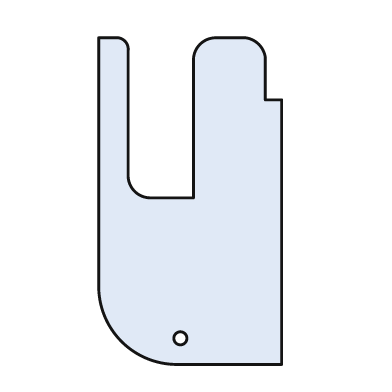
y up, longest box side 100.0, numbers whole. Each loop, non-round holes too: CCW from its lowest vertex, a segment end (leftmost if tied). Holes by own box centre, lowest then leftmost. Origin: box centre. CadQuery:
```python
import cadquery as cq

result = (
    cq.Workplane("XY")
    .moveTo(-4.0, -50.0)
    .lineTo(28.0, -50.0)
    .lineTo(28.0, 31.0)
    .lineTo(23.0, 31.0)
    .lineTo(23.0, 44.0)
    .threePointArc((21.0, 48.0), (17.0, 50.0))
    .lineTo(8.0, 50.0)
    .threePointArc((3.0, 48.0), (1.0, 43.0))
    .lineTo(1.0, 1.0)
    .lineTo(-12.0, 1.0)
    .threePointArc((-17.0, 3.0), (-19.0, 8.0))
    .lineTo(-19.0, 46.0)
    .threePointArc((-20.0, 49.0), (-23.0, 50.0))
    .lineTo(-28.0, 50.0)
    .lineTo(-28.0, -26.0)
    .threePointArc((-21.0, -43.0), (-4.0, -50.0))
    .close()
    .moveTo(-3.0, -42.0)
    .circle(2.0)
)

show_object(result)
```